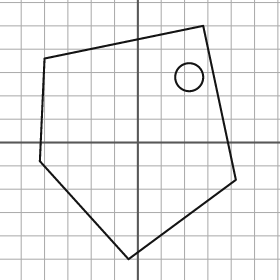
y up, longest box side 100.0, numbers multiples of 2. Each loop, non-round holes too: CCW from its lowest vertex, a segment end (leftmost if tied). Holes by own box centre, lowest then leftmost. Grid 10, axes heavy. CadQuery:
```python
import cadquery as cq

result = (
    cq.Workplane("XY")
    .moveTo(-4.0, -50.0)
    .lineTo(42.0, -16.0)
    .lineTo(28.0, 50.0)
    .lineTo(-40.0, 36.0)
    .lineTo(-42.0, -8.0)
    .close()
    .moveTo(22.0, 28.0)
    .circle(6.0)
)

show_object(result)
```